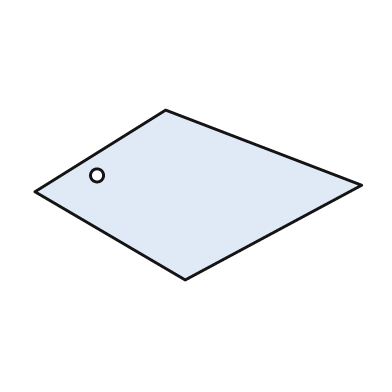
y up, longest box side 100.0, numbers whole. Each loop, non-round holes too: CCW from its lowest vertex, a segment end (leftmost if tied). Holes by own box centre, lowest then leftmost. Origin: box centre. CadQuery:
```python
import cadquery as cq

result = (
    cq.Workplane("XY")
    .moveTo(-4.0, -26.0)
    .lineTo(50.0, 3.0)
    .lineTo(-10.0, 26.0)
    .lineTo(-50.0, 1.0)
    .close()
    .moveTo(-31.0, 6.0)
    .circle(2.0)
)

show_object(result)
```